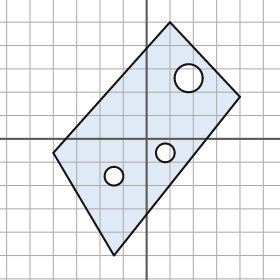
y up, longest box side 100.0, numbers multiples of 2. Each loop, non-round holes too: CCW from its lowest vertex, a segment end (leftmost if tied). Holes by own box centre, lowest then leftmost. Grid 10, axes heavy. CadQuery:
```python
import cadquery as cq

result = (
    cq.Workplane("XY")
    .moveTo(-14.0, -50.0)
    .lineTo(40.0, 18.0)
    .lineTo(10.0, 50.0)
    .lineTo(-40.0, -6.0)
    .close()
    .moveTo(-14.0, -16.0)
    .circle(4.0)
    .moveTo(8.0, -6.0)
    .circle(4.0)
    .moveTo(18.0, 26.0)
    .circle(6.0)
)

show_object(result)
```